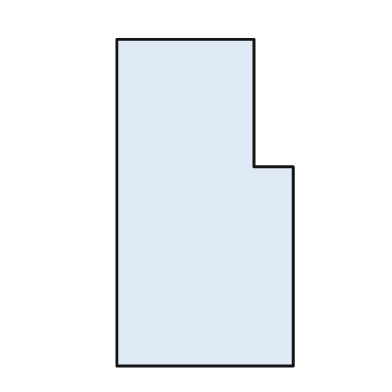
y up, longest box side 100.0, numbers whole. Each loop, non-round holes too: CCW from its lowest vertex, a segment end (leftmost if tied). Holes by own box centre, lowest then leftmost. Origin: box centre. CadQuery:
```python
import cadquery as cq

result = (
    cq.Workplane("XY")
    .moveTo(-27.0, -50.0)
    .lineTo(27.0, -50.0)
    .lineTo(27.0, 11.0)
    .lineTo(15.0, 11.0)
    .lineTo(15.0, 50.0)
    .lineTo(-27.0, 50.0)
    .close()
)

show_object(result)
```